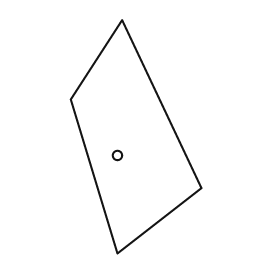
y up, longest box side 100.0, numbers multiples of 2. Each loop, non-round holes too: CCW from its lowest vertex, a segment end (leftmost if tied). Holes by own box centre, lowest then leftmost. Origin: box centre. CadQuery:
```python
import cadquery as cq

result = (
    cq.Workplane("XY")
    .moveTo(-8.0, -50.0)
    .lineTo(28.0, -22.0)
    .lineTo(-6.0, 50.0)
    .lineTo(-28.0, 16.0)
    .close()
    .moveTo(-8.0, -8.0)
    .circle(2.0)
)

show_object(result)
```